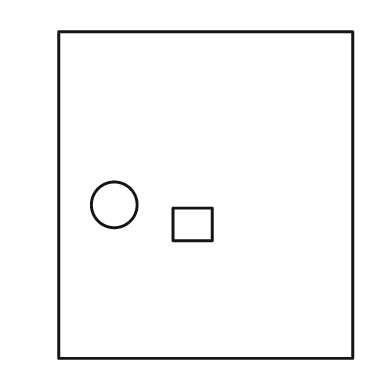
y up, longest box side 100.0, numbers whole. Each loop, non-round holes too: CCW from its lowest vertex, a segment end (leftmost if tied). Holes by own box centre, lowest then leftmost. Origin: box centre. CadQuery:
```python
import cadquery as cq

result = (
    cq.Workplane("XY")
    .moveTo(-45.0, -50.0)
    .lineTo(45.0, -50.0)
    .lineTo(45.0, 50.0)
    .lineTo(-45.0, 50.0)
    .close()
    .moveTo(-10.0, -14.0)
    .lineTo(2.0, -14.0)
    .lineTo(2.0, -4.0)
    .lineTo(-10.0, -4.0)
    .close()
    .moveTo(-28.0, -3.0)
    .circle(7.0)
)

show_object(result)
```